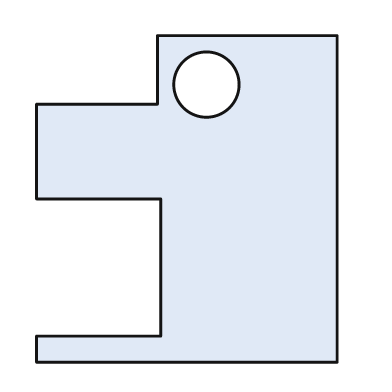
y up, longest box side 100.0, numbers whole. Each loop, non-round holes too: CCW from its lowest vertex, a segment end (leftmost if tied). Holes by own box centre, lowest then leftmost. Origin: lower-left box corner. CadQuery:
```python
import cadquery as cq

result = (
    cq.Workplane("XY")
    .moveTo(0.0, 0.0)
    .lineTo(92.0, 0.0)
    .lineTo(92.0, 100.0)
    .lineTo(37.0, 100.0)
    .lineTo(37.0, 79.0)
    .lineTo(0.0, 79.0)
    .lineTo(0.0, 50.0)
    .lineTo(38.0, 50.0)
    .lineTo(38.0, 8.0)
    .lineTo(0.0, 8.0)
    .close()
    .moveTo(52.0, 85.0)
    .circle(10.0)
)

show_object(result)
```